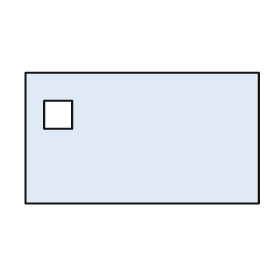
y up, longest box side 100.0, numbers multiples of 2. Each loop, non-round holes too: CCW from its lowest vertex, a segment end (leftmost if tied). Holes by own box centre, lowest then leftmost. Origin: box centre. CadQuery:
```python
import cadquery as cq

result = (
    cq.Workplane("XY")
    .moveTo(-50.0, -28.0)
    .lineTo(50.0, -28.0)
    .lineTo(50.0, 28.0)
    .lineTo(-50.0, 28.0)
    .close()
    .moveTo(-42.0, 4.0)
    .lineTo(-30.0, 4.0)
    .lineTo(-30.0, 16.0)
    .lineTo(-42.0, 16.0)
    .close()
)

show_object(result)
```